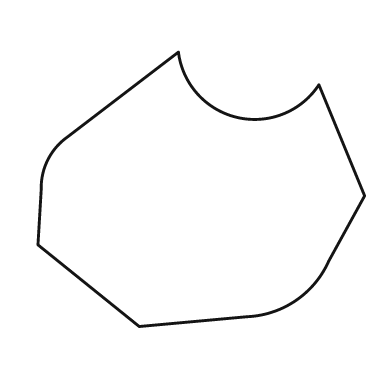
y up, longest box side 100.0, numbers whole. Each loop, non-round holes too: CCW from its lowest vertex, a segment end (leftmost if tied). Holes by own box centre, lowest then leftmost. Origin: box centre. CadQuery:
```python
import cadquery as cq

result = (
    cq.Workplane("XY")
    .moveTo(-19.0, -42.0)
    .lineTo(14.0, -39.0)
    .threePointArc((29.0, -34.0), (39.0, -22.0))
    .lineTo(50.0, -2.0)
    .lineTo(36.0, 32.0)
    .threePointArc((11.0, 22.0), (-7.0, 42.0))
    .lineTo(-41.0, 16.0)
    .threePointArc((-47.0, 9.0), (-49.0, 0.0))
    .lineTo(-50.0, -17.0)
    .close()
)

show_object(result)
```